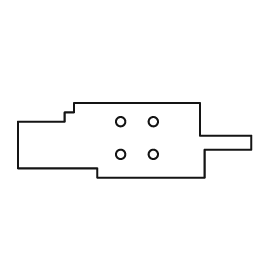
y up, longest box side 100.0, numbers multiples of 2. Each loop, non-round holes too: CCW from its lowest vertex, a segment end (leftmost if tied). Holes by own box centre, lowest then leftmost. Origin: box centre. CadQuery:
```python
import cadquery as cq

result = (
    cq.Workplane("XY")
    .moveTo(-16.0, -16.0)
    .lineTo(30.0, -16.0)
    .lineTo(30.0, -4.0)
    .lineTo(50.0, -4.0)
    .lineTo(50.0, 2.0)
    .lineTo(28.0, 2.0)
    .lineTo(28.0, 16.0)
    .lineTo(-26.0, 16.0)
    .lineTo(-26.0, 12.0)
    .lineTo(-30.0, 12.0)
    .lineTo(-30.0, 8.0)
    .lineTo(-50.0, 8.0)
    .lineTo(-50.0, -12.0)
    .lineTo(-16.0, -12.0)
    .close()
    .moveTo(-6.0, -6.0)
    .circle(2.0)
    .moveTo(8.0, -6.0)
    .circle(2.0)
    .moveTo(-6.0, 8.0)
    .circle(2.0)
    .moveTo(8.0, 8.0)
    .circle(2.0)
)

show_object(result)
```